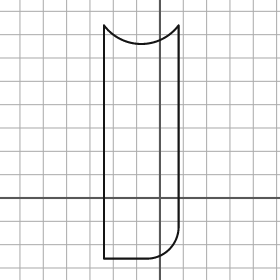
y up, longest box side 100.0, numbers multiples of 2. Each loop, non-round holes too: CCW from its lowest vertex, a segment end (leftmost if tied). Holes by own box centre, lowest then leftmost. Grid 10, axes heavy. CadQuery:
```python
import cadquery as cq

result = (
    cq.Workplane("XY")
    .moveTo(-24.0, -26.0)
    .lineTo(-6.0, -26.0)
    .threePointArc((4.0, -22.0), (8.0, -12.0))
    .lineTo(8.0, 74.0)
    .threePointArc((-8.0, 66.0), (-24.0, 74.0))
    .close()
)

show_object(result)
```